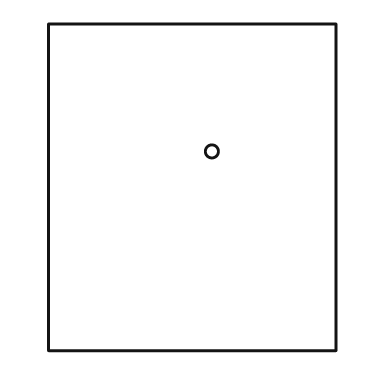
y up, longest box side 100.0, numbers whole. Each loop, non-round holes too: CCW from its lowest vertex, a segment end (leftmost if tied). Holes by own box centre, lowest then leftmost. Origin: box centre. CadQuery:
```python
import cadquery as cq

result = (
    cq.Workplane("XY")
    .moveTo(-44.0, -50.0)
    .lineTo(44.0, -50.0)
    .lineTo(44.0, 50.0)
    .lineTo(-44.0, 50.0)
    .close()
    .moveTo(6.0, 11.0)
    .circle(2.0)
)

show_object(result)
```